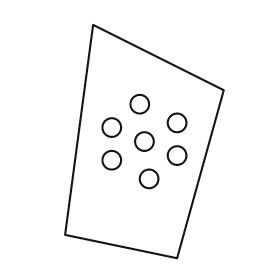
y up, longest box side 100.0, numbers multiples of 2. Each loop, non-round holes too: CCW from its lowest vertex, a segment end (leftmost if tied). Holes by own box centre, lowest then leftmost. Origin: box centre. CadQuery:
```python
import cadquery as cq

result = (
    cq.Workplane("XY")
    .moveTo(14.0, -50.0)
    .lineTo(34.0, 22.0)
    .lineTo(-22.0, 50.0)
    .lineTo(-34.0, -40.0)
    .close()
    .moveTo(2.0, -16.0)
    .circle(4.0)
    .moveTo(-14.0, -8.0)
    .circle(4.0)
    .moveTo(14.0, -6.0)
    .circle(4.0)
    .moveTo(0.0, 0.0)
    .circle(4.0)
    .moveTo(-14.0, 6.0)
    .circle(4.0)
    .moveTo(14.0, 8.0)
    .circle(4.0)
    .moveTo(-2.0, 16.0)
    .circle(4.0)
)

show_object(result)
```